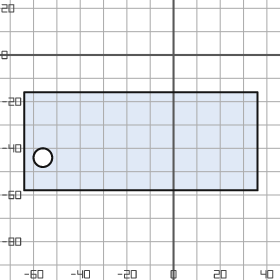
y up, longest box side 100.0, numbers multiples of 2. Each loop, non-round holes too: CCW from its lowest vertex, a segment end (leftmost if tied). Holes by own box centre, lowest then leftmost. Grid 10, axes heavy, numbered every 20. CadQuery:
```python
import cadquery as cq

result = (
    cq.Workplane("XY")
    .moveTo(-64.0, -58.0)
    .lineTo(36.0, -58.0)
    .lineTo(36.0, -16.0)
    .lineTo(-64.0, -16.0)
    .close()
    .moveTo(-56.0, -44.0)
    .circle(4.0)
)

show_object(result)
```